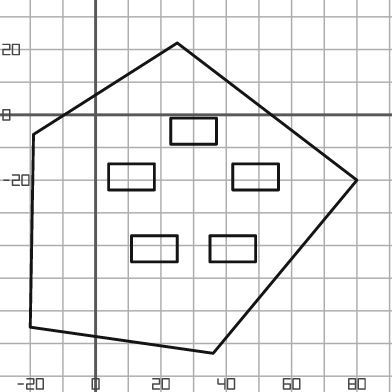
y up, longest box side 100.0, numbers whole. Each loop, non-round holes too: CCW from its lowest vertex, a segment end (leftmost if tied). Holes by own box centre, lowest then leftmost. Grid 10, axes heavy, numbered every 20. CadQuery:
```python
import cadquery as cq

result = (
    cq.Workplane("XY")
    .moveTo(36.0, -73.0)
    .lineTo(80.0, -20.0)
    .lineTo(25.0, 22.0)
    .lineTo(-19.0, -6.0)
    .lineTo(-20.0, -65.0)
    .close()
    .moveTo(11.0, -45.0)
    .lineTo(25.0, -45.0)
    .lineTo(25.0, -37.0)
    .lineTo(11.0, -37.0)
    .close()
    .moveTo(35.0, -45.0)
    .lineTo(49.0, -45.0)
    .lineTo(49.0, -37.0)
    .lineTo(35.0, -37.0)
    .close()
    .moveTo(4.0, -23.0)
    .lineTo(18.0, -23.0)
    .lineTo(18.0, -15.0)
    .lineTo(4.0, -15.0)
    .close()
    .moveTo(42.0, -23.0)
    .lineTo(56.0, -23.0)
    .lineTo(56.0, -15.0)
    .lineTo(42.0, -15.0)
    .close()
    .moveTo(23.0, -9.0)
    .lineTo(37.0, -9.0)
    .lineTo(37.0, -1.0)
    .lineTo(23.0, -1.0)
    .close()
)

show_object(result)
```